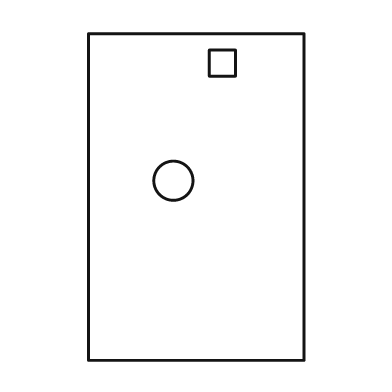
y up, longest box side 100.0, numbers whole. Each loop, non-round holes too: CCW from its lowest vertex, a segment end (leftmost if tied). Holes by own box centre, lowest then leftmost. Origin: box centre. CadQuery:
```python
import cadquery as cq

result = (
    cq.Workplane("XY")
    .moveTo(-33.0, -50.0)
    .lineTo(33.0, -50.0)
    .lineTo(33.0, 50.0)
    .lineTo(-33.0, 50.0)
    .close()
    .moveTo(-7.0, 5.0)
    .circle(6.0)
    .moveTo(4.0, 37.0)
    .lineTo(12.0, 37.0)
    .lineTo(12.0, 45.0)
    .lineTo(4.0, 45.0)
    .close()
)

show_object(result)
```